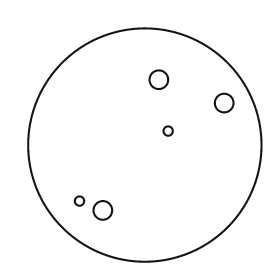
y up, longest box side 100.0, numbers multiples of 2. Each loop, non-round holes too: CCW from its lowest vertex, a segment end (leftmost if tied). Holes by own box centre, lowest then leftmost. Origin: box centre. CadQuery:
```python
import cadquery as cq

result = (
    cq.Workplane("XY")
    .moveTo(0.0, 0.0)
    .circle(50.0)
    .moveTo(-18.0, -28.0)
    .circle(4.0)
    .moveTo(-28.0, -24.0)
    .circle(2.0)
    .moveTo(10.0, 6.0)
    .circle(2.0)
    .moveTo(34.0, 18.0)
    .circle(4.0)
    .moveTo(6.0, 28.0)
    .circle(4.0)
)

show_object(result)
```